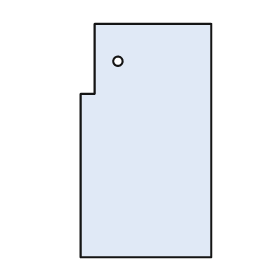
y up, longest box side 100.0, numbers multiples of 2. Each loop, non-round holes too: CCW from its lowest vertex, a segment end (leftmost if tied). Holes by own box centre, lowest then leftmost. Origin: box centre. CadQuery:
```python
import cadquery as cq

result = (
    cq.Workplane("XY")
    .moveTo(-28.0, -50.0)
    .lineTo(28.0, -50.0)
    .lineTo(28.0, 50.0)
    .lineTo(-22.0, 50.0)
    .lineTo(-22.0, 20.0)
    .lineTo(-28.0, 20.0)
    .close()
    .moveTo(-12.0, 34.0)
    .circle(2.0)
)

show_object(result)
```